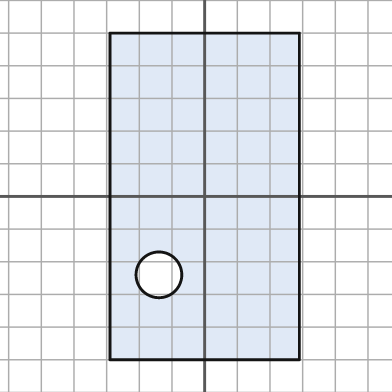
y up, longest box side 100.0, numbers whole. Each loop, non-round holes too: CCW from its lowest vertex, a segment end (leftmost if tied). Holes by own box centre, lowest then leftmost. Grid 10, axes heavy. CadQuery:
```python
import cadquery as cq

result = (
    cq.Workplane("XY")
    .moveTo(-29.0, -50.0)
    .lineTo(29.0, -50.0)
    .lineTo(29.0, 50.0)
    .lineTo(-29.0, 50.0)
    .close()
    .moveTo(-14.0, -24.0)
    .circle(7.0)
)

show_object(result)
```